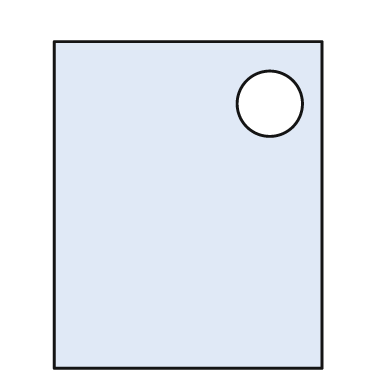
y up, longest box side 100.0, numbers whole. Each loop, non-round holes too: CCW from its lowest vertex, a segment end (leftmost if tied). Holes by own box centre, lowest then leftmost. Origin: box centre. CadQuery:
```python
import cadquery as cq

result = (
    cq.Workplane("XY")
    .moveTo(-41.0, -50.0)
    .lineTo(41.0, -50.0)
    .lineTo(41.0, 50.0)
    .lineTo(-41.0, 50.0)
    .close()
    .moveTo(25.0, 31.0)
    .circle(10.0)
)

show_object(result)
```